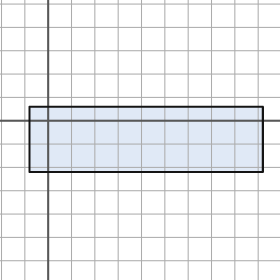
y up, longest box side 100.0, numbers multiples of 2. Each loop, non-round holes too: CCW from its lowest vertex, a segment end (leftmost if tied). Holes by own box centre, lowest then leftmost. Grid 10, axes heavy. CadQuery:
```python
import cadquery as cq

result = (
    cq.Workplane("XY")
    .moveTo(-8.0, -22.0)
    .lineTo(92.0, -22.0)
    .lineTo(92.0, 6.0)
    .lineTo(-8.0, 6.0)
    .close()
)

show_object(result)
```